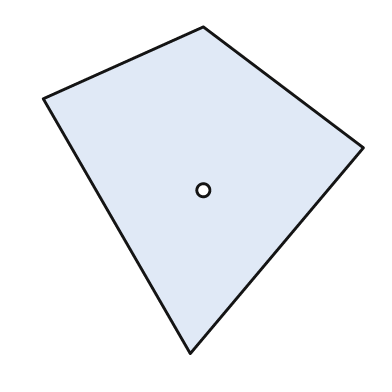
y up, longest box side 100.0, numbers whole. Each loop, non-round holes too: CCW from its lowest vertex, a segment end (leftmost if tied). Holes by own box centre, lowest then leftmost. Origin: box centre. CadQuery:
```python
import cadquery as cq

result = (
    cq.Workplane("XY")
    .moveTo(-4.0, -50.0)
    .lineTo(49.0, 13.0)
    .lineTo(0.0, 50.0)
    .lineTo(-49.0, 28.0)
    .close()
    .moveTo(0.0, 0.0)
    .circle(2.0)
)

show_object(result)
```